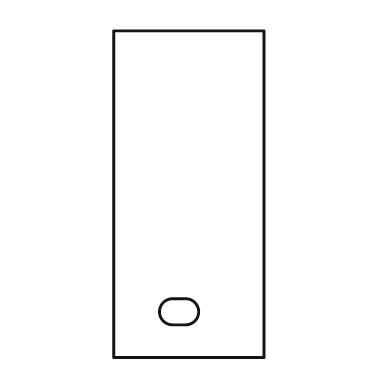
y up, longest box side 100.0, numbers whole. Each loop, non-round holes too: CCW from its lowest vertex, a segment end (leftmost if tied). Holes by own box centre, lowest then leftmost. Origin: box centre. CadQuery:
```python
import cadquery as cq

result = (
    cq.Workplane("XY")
    .moveTo(-23.0, -50.0)
    .lineTo(23.0, -50.0)
    .lineTo(23.0, 50.0)
    .lineTo(-23.0, 50.0)
    .close()
    .moveTo(-5.0, -40.0)
    .lineTo(-1.0, -40.0)
    .threePointArc((3.0, -36.0), (-1.0, -32.0))
    .lineTo(-5.0, -32.0)
    .threePointArc((-9.0, -36.0), (-5.0, -40.0))
    .close()
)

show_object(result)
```